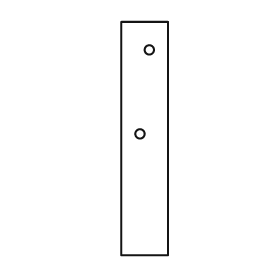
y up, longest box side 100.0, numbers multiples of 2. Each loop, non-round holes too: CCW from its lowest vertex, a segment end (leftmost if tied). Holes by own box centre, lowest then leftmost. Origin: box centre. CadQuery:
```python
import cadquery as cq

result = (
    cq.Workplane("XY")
    .moveTo(-10.0, -50.0)
    .lineTo(10.0, -50.0)
    .lineTo(10.0, 50.0)
    .lineTo(-10.0, 50.0)
    .close()
    .moveTo(-2.0, 2.0)
    .circle(2.0)
    .moveTo(2.0, 38.0)
    .circle(2.0)
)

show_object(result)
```